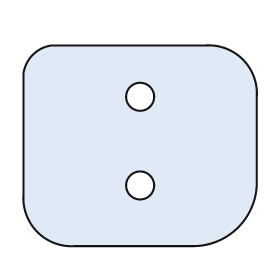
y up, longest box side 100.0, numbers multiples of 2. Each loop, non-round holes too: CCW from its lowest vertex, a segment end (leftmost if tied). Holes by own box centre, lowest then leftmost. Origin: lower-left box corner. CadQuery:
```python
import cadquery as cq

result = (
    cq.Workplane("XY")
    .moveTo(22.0, 0.0)
    .lineTo(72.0, 0.0)
    .threePointArc((92.0, 8.0), (100.0, 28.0))
    .lineTo(100.0, 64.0)
    .threePointArc((94.0, 80.0), (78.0, 86.0))
    .lineTo(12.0, 86.0)
    .threePointArc((4.0, 82.0), (0.0, 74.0))
    .lineTo(0.0, 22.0)
    .threePointArc((6.0, 6.0), (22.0, 0.0))
    .close()
    .moveTo(50.0, 26.0)
    .circle(6.0)
    .moveTo(50.0, 64.0)
    .circle(6.0)
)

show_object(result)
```